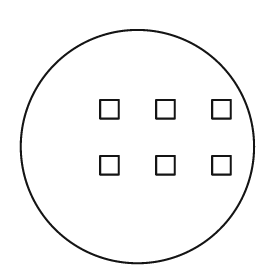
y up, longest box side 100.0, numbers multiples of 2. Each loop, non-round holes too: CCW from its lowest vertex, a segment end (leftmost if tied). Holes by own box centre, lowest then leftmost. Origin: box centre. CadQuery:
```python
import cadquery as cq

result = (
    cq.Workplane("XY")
    .moveTo(0.0, 0.0)
    .circle(50.0)
    .moveTo(-16.0, -12.0)
    .lineTo(-8.0, -12.0)
    .lineTo(-8.0, -4.0)
    .lineTo(-16.0, -4.0)
    .close()
    .moveTo(8.0, -12.0)
    .lineTo(16.0, -12.0)
    .lineTo(16.0, -4.0)
    .lineTo(8.0, -4.0)
    .close()
    .moveTo(32.0, -12.0)
    .lineTo(40.0, -12.0)
    .lineTo(40.0, -4.0)
    .lineTo(32.0, -4.0)
    .close()
    .moveTo(-16.0, 12.0)
    .lineTo(-8.0, 12.0)
    .lineTo(-8.0, 20.0)
    .lineTo(-16.0, 20.0)
    .close()
    .moveTo(8.0, 12.0)
    .lineTo(16.0, 12.0)
    .lineTo(16.0, 20.0)
    .lineTo(8.0, 20.0)
    .close()
    .moveTo(32.0, 12.0)
    .lineTo(40.0, 12.0)
    .lineTo(40.0, 20.0)
    .lineTo(32.0, 20.0)
    .close()
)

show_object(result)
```